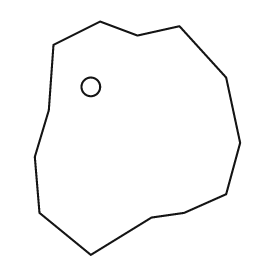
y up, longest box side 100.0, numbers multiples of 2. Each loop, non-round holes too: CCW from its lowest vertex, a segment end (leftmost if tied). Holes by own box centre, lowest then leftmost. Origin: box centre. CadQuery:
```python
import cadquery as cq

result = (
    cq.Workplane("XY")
    .moveTo(-20.0, -50.0)
    .lineTo(6.0, -34.0)
    .lineTo(20.0, -32.0)
    .lineTo(38.0, -24.0)
    .lineTo(44.0, -2.0)
    .lineTo(38.0, 26.0)
    .lineTo(18.0, 48.0)
    .lineTo(0.0, 44.0)
    .lineTo(-16.0, 50.0)
    .lineTo(-36.0, 40.0)
    .lineTo(-38.0, 12.0)
    .lineTo(-44.0, -8.0)
    .lineTo(-42.0, -32.0)
    .close()
    .moveTo(-20.0, 22.0)
    .circle(4.0)
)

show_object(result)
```